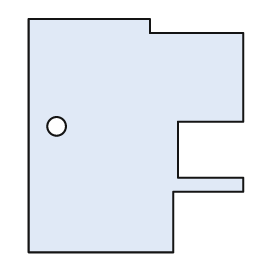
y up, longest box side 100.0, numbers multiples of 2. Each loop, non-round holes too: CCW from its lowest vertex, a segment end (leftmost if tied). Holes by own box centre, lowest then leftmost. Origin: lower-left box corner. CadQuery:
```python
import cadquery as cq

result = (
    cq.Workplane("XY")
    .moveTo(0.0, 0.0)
    .lineTo(62.0, 0.0)
    .lineTo(62.0, 26.0)
    .lineTo(92.0, 26.0)
    .lineTo(92.0, 32.0)
    .lineTo(64.0, 32.0)
    .lineTo(64.0, 56.0)
    .lineTo(92.0, 56.0)
    .lineTo(92.0, 94.0)
    .lineTo(52.0, 94.0)
    .lineTo(52.0, 100.0)
    .lineTo(0.0, 100.0)
    .close()
    .moveTo(12.0, 54.0)
    .circle(4.0)
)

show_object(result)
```